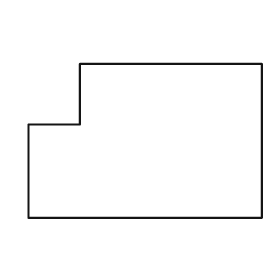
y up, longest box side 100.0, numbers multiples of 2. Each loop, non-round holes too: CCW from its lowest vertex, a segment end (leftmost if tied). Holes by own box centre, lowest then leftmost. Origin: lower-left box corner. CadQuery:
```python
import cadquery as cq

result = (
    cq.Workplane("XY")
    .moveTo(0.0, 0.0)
    .lineTo(100.0, 0.0)
    .lineTo(100.0, 66.0)
    .lineTo(22.0, 66.0)
    .lineTo(22.0, 40.0)
    .lineTo(0.0, 40.0)
    .close()
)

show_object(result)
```